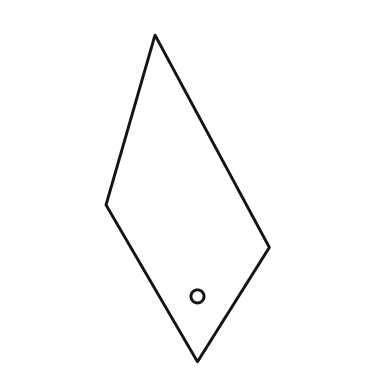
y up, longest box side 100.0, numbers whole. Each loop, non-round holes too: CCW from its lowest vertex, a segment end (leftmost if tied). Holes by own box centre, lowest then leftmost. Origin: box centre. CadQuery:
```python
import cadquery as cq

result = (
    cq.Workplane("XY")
    .moveTo(3.0, -50.0)
    .lineTo(25.0, -15.0)
    .lineTo(-10.0, 50.0)
    .lineTo(-25.0, -2.0)
    .close()
    .moveTo(3.0, -30.0)
    .circle(2.0)
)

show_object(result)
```